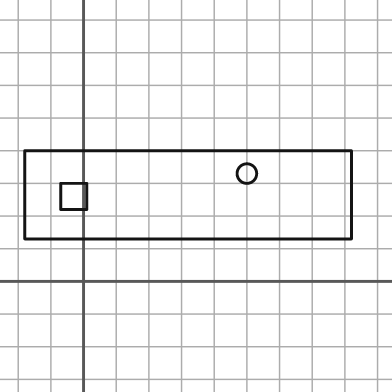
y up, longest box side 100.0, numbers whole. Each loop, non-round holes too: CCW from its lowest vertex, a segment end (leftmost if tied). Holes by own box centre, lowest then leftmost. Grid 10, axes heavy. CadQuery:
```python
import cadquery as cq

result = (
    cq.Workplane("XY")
    .moveTo(-18.0, 13.0)
    .lineTo(82.0, 13.0)
    .lineTo(82.0, 40.0)
    .lineTo(-18.0, 40.0)
    .close()
    .moveTo(-7.0, 22.0)
    .lineTo(1.0, 22.0)
    .lineTo(1.0, 30.0)
    .lineTo(-7.0, 30.0)
    .close()
    .moveTo(50.0, 33.0)
    .circle(3.0)
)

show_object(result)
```